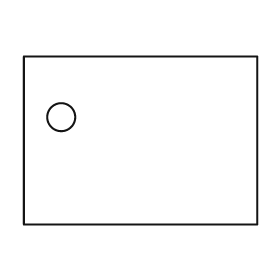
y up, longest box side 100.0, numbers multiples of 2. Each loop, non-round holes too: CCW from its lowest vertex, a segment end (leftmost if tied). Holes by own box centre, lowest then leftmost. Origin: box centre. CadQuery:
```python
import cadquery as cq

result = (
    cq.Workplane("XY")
    .moveTo(-50.0, -36.0)
    .lineTo(50.0, -36.0)
    .lineTo(50.0, 36.0)
    .lineTo(-50.0, 36.0)
    .close()
    .moveTo(-34.0, 10.0)
    .circle(6.0)
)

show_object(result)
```